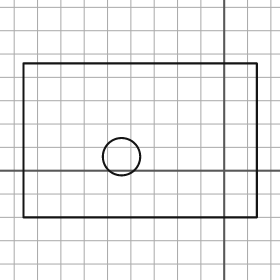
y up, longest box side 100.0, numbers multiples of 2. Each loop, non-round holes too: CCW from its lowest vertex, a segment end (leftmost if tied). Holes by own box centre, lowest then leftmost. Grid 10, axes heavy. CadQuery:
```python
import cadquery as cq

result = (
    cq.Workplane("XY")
    .moveTo(-86.0, -20.0)
    .lineTo(14.0, -20.0)
    .lineTo(14.0, 46.0)
    .lineTo(-86.0, 46.0)
    .close()
    .moveTo(-44.0, 6.0)
    .circle(8.0)
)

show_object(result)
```